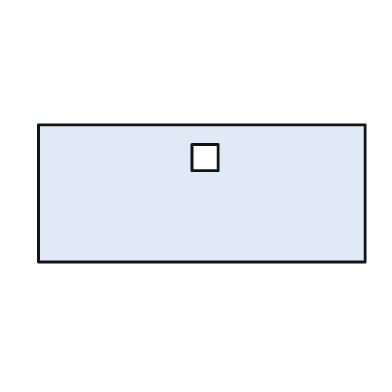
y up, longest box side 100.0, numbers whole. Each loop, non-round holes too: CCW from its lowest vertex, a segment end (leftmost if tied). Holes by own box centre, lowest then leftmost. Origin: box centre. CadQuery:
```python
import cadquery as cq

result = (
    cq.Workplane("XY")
    .moveTo(-50.0, -21.0)
    .lineTo(50.0, -21.0)
    .lineTo(50.0, 21.0)
    .lineTo(-50.0, 21.0)
    .close()
    .moveTo(-3.0, 7.0)
    .lineTo(5.0, 7.0)
    .lineTo(5.0, 15.0)
    .lineTo(-3.0, 15.0)
    .close()
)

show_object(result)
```